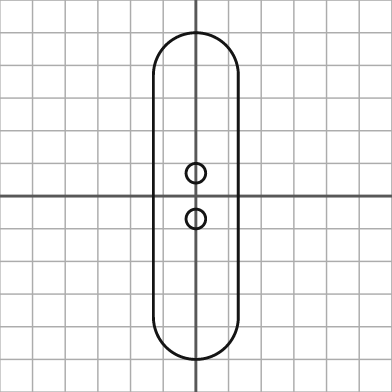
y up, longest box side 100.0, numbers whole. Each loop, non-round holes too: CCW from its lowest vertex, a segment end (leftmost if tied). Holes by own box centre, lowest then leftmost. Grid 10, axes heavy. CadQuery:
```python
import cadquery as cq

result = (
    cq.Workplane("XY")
    .moveTo(-13.0, -37.0)
    .threePointArc((0.0, -50.0), (13.0, -37.0))
    .lineTo(13.0, 37.0)
    .threePointArc((0.0, 50.0), (-13.0, 37.0))
    .close()
    .moveTo(0.0, -7.0)
    .circle(3.0)
    .moveTo(0.0, 7.0)
    .circle(3.0)
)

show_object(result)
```